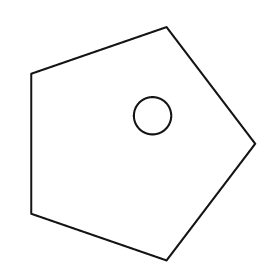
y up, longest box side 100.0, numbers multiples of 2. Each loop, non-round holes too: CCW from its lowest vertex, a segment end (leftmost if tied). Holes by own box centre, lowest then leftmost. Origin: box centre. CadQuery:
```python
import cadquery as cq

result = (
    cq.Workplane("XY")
    .moveTo(10.0, -50.0)
    .lineTo(48.0, 0.0)
    .lineTo(10.0, 50.0)
    .lineTo(-48.0, 30.0)
    .lineTo(-48.0, -30.0)
    .close()
    .moveTo(4.0, 12.0)
    .circle(8.0)
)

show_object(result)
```